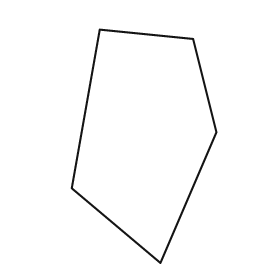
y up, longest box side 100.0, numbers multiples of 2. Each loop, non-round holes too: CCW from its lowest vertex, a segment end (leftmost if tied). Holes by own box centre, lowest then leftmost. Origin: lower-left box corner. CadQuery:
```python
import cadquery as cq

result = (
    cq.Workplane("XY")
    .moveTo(38.0, 0.0)
    .lineTo(62.0, 56.0)
    .lineTo(52.0, 96.0)
    .lineTo(12.0, 100.0)
    .lineTo(0.0, 32.0)
    .close()
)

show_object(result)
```